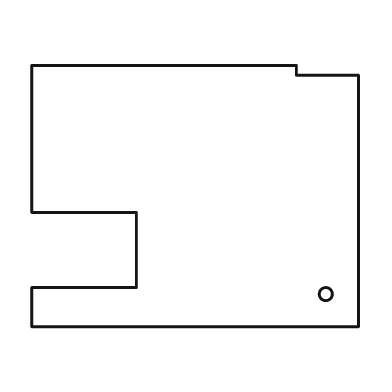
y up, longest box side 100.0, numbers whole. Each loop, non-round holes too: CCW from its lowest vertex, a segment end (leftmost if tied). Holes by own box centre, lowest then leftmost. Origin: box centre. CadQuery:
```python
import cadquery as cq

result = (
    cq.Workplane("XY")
    .moveTo(-50.0, -40.0)
    .lineTo(50.0, -40.0)
    .lineTo(50.0, 37.0)
    .lineTo(31.0, 37.0)
    .lineTo(31.0, 40.0)
    .lineTo(-50.0, 40.0)
    .lineTo(-50.0, -5.0)
    .lineTo(-18.0, -5.0)
    .lineTo(-18.0, -28.0)
    .lineTo(-50.0, -28.0)
    .close()
    .moveTo(40.0, -30.0)
    .circle(2.0)
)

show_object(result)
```